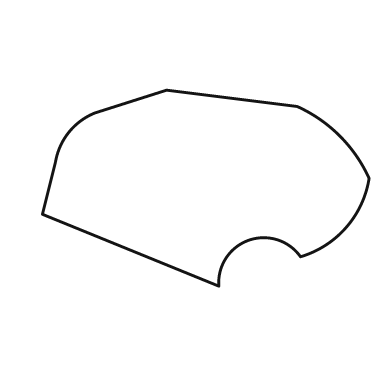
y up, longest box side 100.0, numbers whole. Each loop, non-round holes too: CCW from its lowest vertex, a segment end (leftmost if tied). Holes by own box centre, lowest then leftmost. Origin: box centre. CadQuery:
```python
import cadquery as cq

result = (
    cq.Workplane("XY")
    .moveTo(4.0, -30.0)
    .threePointArc((13.0, -16.0), (29.0, -21.0))
    .threePointArc((43.0, -12.0), (50.0, 3.0))
    .threePointArc((41.0, 16.0), (28.0, 25.0))
    .lineTo(-12.0, 30.0)
    .lineTo(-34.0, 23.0)
    .threePointArc((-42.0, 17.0), (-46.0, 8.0))
    .lineTo(-50.0, -8.0)
    .close()
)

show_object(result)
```